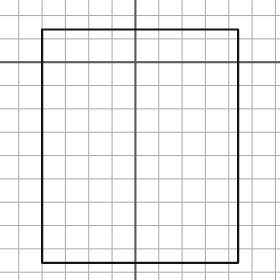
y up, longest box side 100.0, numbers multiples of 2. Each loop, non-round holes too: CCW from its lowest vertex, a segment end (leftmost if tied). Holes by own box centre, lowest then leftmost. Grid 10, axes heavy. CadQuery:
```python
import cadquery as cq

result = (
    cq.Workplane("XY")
    .moveTo(-40.0, -86.0)
    .lineTo(44.0, -86.0)
    .lineTo(44.0, 14.0)
    .lineTo(-40.0, 14.0)
    .close()
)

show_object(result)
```